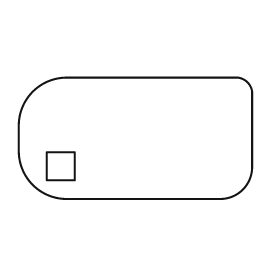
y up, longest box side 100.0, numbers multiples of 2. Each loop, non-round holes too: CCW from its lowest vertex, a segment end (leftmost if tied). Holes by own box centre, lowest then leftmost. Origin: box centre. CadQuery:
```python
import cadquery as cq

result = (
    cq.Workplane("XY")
    .moveTo(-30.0, -26.0)
    .lineTo(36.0, -26.0)
    .threePointArc((46.0, -22.0), (50.0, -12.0))
    .lineTo(50.0, 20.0)
    .threePointArc((48.0, 24.0), (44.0, 26.0))
    .lineTo(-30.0, 26.0)
    .threePointArc((-44.0, 20.0), (-50.0, 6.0))
    .lineTo(-50.0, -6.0)
    .threePointArc((-44.0, -20.0), (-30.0, -26.0))
    .close()
    .moveTo(-38.0, -18.0)
    .lineTo(-26.0, -18.0)
    .lineTo(-26.0, -6.0)
    .lineTo(-38.0, -6.0)
    .close()
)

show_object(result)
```